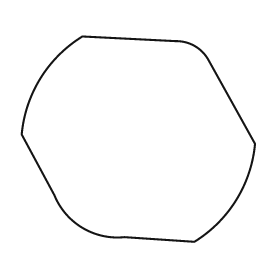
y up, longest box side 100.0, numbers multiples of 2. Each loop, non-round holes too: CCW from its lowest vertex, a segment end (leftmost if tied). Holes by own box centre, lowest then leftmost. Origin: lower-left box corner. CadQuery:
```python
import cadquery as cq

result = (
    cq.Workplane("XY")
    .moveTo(74.0, 0.0)
    .threePointArc((92.0, 18.0), (100.0, 42.0))
    .lineTo(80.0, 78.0)
    .threePointArc((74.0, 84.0), (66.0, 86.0))
    .lineTo(26.0, 88.0)
    .threePointArc((8.0, 70.0), (0.0, 46.0))
    .lineTo(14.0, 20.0)
    .threePointArc((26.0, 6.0), (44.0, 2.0))
    .close()
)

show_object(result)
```